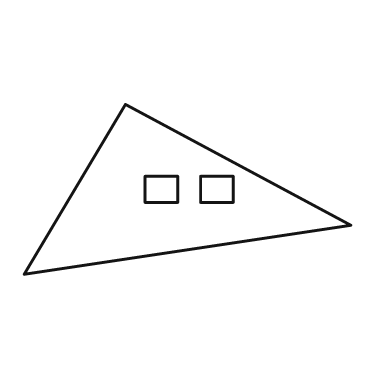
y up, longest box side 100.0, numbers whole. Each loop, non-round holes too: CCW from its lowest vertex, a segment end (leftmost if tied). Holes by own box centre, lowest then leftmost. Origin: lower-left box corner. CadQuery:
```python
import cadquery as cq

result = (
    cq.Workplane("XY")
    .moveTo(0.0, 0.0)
    .lineTo(100.0, 15.0)
    .lineTo(31.0, 52.0)
    .close()
    .moveTo(37.0, 22.0)
    .lineTo(47.0, 22.0)
    .lineTo(47.0, 30.0)
    .lineTo(37.0, 30.0)
    .close()
    .moveTo(54.0, 22.0)
    .lineTo(64.0, 22.0)
    .lineTo(64.0, 30.0)
    .lineTo(54.0, 30.0)
    .close()
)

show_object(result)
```